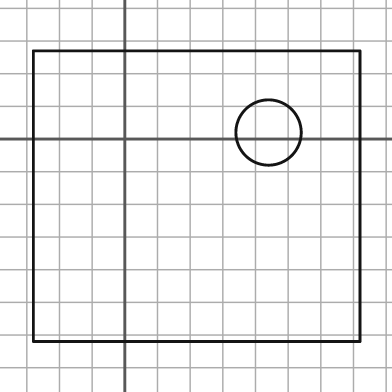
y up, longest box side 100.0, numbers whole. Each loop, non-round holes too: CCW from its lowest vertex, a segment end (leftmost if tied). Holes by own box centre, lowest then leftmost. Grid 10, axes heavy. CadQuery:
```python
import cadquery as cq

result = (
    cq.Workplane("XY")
    .moveTo(-28.0, -62.0)
    .lineTo(72.0, -62.0)
    .lineTo(72.0, 27.0)
    .lineTo(-28.0, 27.0)
    .close()
    .moveTo(44.0, 2.0)
    .circle(10.0)
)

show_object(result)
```